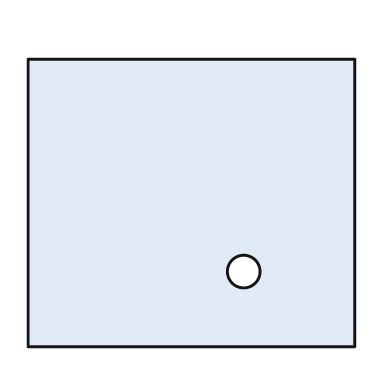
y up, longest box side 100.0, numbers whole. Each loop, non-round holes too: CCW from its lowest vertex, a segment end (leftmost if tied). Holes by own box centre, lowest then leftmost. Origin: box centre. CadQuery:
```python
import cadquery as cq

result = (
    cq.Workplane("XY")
    .moveTo(-50.0, -44.0)
    .lineTo(50.0, -44.0)
    .lineTo(50.0, 44.0)
    .lineTo(-50.0, 44.0)
    .close()
    .moveTo(16.0, -21.0)
    .circle(5.0)
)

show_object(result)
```